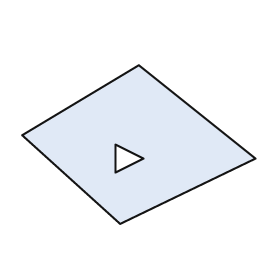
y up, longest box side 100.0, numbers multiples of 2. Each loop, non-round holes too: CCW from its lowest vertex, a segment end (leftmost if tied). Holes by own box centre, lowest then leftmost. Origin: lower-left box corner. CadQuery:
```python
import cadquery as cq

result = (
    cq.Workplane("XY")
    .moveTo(42.0, 0.0)
    .lineTo(100.0, 28.0)
    .lineTo(50.0, 68.0)
    .lineTo(0.0, 38.0)
    .close()
    .moveTo(40.0, 22.0)
    .lineTo(52.0, 28.0)
    .lineTo(40.0, 34.0)
    .close()
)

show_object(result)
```